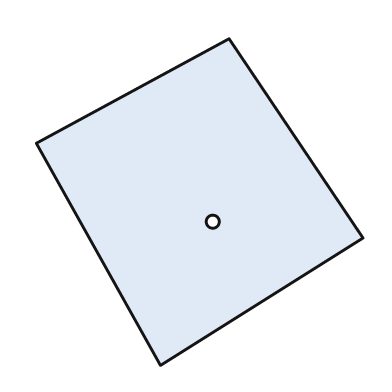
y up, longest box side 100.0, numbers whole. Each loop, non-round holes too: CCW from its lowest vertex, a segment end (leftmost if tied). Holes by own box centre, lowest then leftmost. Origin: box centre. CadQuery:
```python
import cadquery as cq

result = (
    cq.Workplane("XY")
    .moveTo(-12.0, -50.0)
    .lineTo(50.0, -11.0)
    .lineTo(9.0, 50.0)
    .lineTo(-50.0, 18.0)
    .close()
    .moveTo(4.0, -6.0)
    .circle(2.0)
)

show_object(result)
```